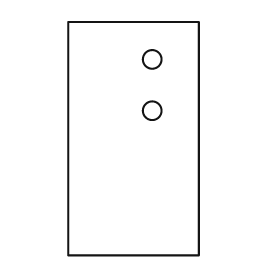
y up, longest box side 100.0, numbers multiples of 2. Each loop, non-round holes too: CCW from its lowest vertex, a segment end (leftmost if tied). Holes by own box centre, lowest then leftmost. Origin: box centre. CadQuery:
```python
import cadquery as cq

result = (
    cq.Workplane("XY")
    .moveTo(-28.0, -50.0)
    .lineTo(28.0, -50.0)
    .lineTo(28.0, 50.0)
    .lineTo(-28.0, 50.0)
    .close()
    .moveTo(8.0, 12.0)
    .circle(4.0)
    .moveTo(8.0, 34.0)
    .circle(4.0)
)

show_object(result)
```